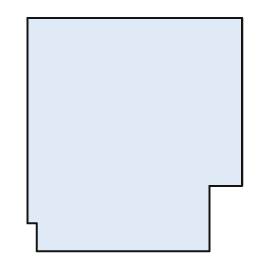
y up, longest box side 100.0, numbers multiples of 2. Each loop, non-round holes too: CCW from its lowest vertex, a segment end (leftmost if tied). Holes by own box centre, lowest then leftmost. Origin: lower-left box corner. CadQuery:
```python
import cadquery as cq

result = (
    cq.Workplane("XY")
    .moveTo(4.0, 0.0)
    .lineTo(78.0, 0.0)
    .lineTo(78.0, 28.0)
    .lineTo(92.0, 28.0)
    .lineTo(92.0, 100.0)
    .lineTo(0.0, 100.0)
    .lineTo(0.0, 12.0)
    .lineTo(4.0, 12.0)
    .close()
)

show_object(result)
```